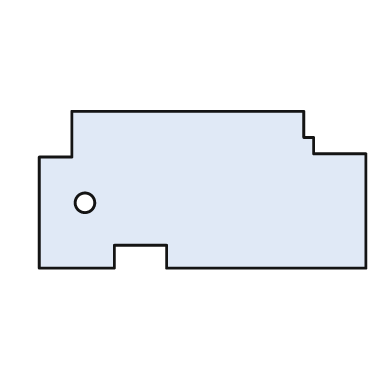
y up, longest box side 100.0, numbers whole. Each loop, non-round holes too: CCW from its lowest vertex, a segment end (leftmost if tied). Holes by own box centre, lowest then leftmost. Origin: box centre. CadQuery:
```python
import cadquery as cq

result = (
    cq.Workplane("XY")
    .moveTo(-50.0, -24.0)
    .lineTo(-27.0, -24.0)
    .lineTo(-27.0, -17.0)
    .lineTo(-11.0, -17.0)
    .lineTo(-11.0, -24.0)
    .lineTo(50.0, -24.0)
    .lineTo(50.0, 11.0)
    .lineTo(34.0, 11.0)
    .lineTo(34.0, 16.0)
    .lineTo(31.0, 16.0)
    .lineTo(31.0, 24.0)
    .lineTo(-40.0, 24.0)
    .lineTo(-40.0, 10.0)
    .lineTo(-50.0, 10.0)
    .close()
    .moveTo(-36.0, -4.0)
    .circle(3.0)
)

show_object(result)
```